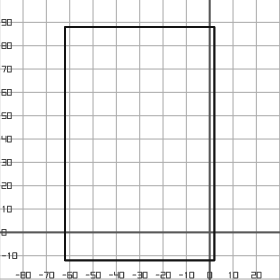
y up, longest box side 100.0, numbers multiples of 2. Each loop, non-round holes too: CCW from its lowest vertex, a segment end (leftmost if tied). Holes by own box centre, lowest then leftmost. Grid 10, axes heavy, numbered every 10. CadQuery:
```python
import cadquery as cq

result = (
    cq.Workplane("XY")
    .moveTo(-62.0, -12.0)
    .lineTo(2.0, -12.0)
    .lineTo(2.0, 88.0)
    .lineTo(-62.0, 88.0)
    .close()
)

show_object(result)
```